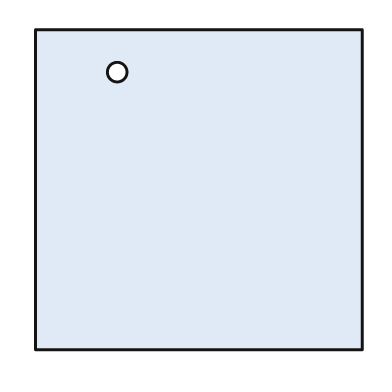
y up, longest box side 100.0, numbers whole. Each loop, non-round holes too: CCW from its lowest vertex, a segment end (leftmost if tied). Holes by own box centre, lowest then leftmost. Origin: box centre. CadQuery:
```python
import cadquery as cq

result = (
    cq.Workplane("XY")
    .moveTo(-50.0, -49.0)
    .lineTo(50.0, -49.0)
    .lineTo(50.0, 49.0)
    .lineTo(-50.0, 49.0)
    .close()
    .moveTo(-25.0, 36.0)
    .circle(3.0)
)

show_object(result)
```